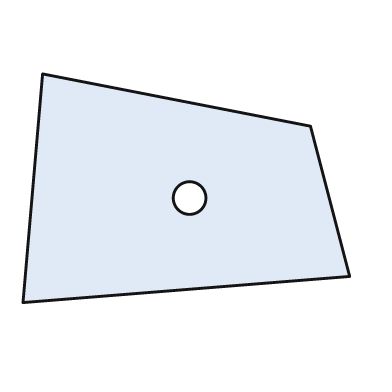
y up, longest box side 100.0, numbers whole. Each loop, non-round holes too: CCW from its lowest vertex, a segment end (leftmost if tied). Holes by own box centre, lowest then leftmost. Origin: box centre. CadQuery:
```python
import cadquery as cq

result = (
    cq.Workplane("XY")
    .moveTo(-50.0, -35.0)
    .lineTo(50.0, -27.0)
    .lineTo(38.0, 19.0)
    .lineTo(-44.0, 35.0)
    .close()
    .moveTo(1.0, -3.0)
    .circle(5.0)
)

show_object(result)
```